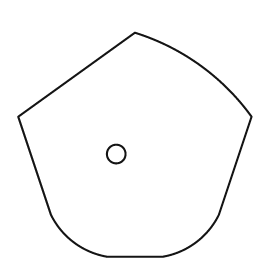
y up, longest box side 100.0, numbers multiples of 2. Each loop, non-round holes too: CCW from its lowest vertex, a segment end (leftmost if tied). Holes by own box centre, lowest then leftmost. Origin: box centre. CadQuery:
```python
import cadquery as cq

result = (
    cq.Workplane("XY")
    .moveTo(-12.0, -48.0)
    .lineTo(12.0, -48.0)
    .threePointArc((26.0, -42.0), (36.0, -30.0))
    .lineTo(50.0, 12.0)
    .threePointArc((28.0, 34.0), (0.0, 48.0))
    .lineTo(-50.0, 12.0)
    .lineTo(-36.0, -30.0)
    .threePointArc((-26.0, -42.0), (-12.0, -48.0))
    .close()
    .moveTo(-8.0, -4.0)
    .circle(4.0)
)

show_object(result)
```